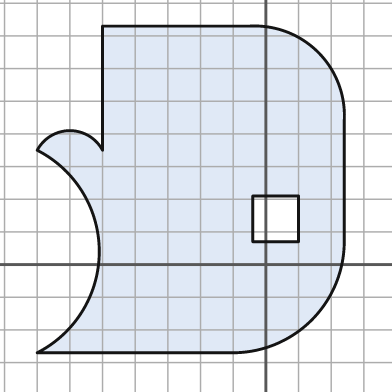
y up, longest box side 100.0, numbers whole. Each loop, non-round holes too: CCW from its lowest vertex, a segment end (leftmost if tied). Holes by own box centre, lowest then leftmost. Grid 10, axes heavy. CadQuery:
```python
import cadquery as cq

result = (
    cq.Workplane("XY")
    .moveTo(-70.0, -27.0)
    .lineTo(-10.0, -27.0)
    .threePointArc((14.0, -17.0), (24.0, 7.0))
    .lineTo(24.0, 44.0)
    .threePointArc((16.0, 65.0), (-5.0, 73.0))
    .lineTo(-50.0, 73.0)
    .lineTo(-50.0, 35.0)
    .threePointArc((-60.0, 41.0), (-70.0, 35.0))
    .threePointArc((-51.0, 4.0), (-70.0, -27.0))
    .close()
    .moveTo(-4.0, 7.0)
    .lineTo(10.0, 7.0)
    .lineTo(10.0, 21.0)
    .lineTo(-4.0, 21.0)
    .close()
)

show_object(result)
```